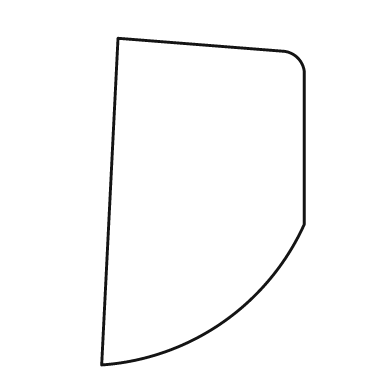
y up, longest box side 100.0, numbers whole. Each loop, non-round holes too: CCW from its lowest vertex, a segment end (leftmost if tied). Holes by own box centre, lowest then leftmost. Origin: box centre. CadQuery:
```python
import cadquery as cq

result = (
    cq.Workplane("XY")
    .moveTo(-31.0, -50.0)
    .threePointArc((6.0, -37.0), (31.0, -7.0))
    .lineTo(31.0, 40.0)
    .threePointArc((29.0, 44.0), (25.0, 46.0))
    .lineTo(-26.0, 50.0)
    .close()
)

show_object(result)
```